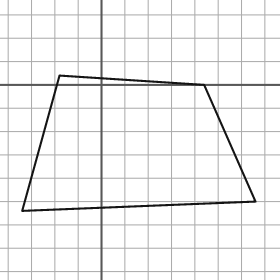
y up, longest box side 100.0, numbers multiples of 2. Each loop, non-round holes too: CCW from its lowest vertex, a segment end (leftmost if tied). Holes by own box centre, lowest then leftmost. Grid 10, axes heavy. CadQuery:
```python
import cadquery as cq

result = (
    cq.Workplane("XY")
    .moveTo(-34.0, -54.0)
    .lineTo(66.0, -50.0)
    .lineTo(44.0, 0.0)
    .lineTo(-18.0, 4.0)
    .close()
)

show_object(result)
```